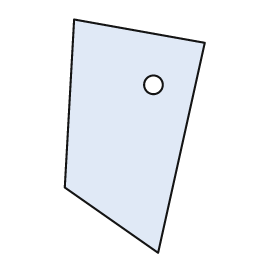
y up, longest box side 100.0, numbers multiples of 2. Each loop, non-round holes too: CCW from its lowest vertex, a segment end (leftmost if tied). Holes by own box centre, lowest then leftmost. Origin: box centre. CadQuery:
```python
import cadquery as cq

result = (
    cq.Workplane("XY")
    .moveTo(10.0, -50.0)
    .lineTo(30.0, 40.0)
    .lineTo(-26.0, 50.0)
    .lineTo(-30.0, -22.0)
    .close()
    .moveTo(8.0, 22.0)
    .circle(4.0)
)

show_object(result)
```